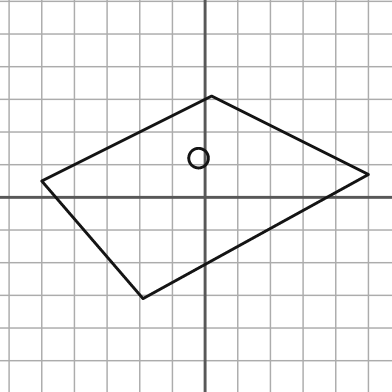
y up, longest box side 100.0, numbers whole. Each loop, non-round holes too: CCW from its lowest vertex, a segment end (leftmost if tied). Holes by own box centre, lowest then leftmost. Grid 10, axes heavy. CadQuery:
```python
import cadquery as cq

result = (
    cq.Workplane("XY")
    .moveTo(-19.0, -31.0)
    .lineTo(50.0, 7.0)
    .lineTo(2.0, 31.0)
    .lineTo(-50.0, 5.0)
    .close()
    .moveTo(-2.0, 12.0)
    .circle(3.0)
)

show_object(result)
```